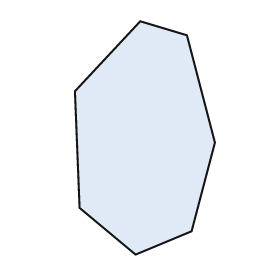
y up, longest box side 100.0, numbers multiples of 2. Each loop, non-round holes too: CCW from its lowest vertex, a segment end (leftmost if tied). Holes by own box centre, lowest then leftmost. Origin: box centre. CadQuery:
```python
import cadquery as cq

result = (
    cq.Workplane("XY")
    .moveTo(-4.0, -50.0)
    .lineTo(20.0, -40.0)
    .lineTo(30.0, -2.0)
    .lineTo(18.0, 44.0)
    .lineTo(-2.0, 50.0)
    .lineTo(-30.0, 20.0)
    .lineTo(-28.0, -30.0)
    .close()
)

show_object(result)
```